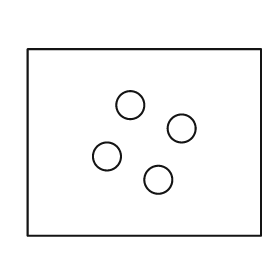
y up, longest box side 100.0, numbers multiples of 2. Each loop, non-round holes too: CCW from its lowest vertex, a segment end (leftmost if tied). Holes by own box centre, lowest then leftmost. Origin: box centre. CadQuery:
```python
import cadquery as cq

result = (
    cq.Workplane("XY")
    .moveTo(-50.0, -40.0)
    .lineTo(50.0, -40.0)
    .lineTo(50.0, 40.0)
    .lineTo(-50.0, 40.0)
    .close()
    .moveTo(6.0, -16.0)
    .circle(6.0)
    .moveTo(-16.0, -6.0)
    .circle(6.0)
    .moveTo(16.0, 6.0)
    .circle(6.0)
    .moveTo(-6.0, 16.0)
    .circle(6.0)
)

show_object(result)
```